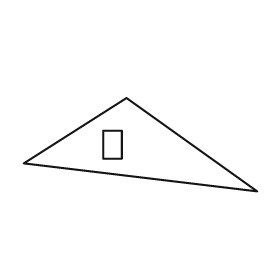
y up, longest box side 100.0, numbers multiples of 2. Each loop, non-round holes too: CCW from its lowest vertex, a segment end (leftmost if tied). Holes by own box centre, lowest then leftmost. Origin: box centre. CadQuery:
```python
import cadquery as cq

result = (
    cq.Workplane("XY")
    .moveTo(50.0, -20.0)
    .lineTo(-6.0, 20.0)
    .lineTo(-50.0, -8.0)
    .close()
    .moveTo(-16.0, -6.0)
    .lineTo(-8.0, -6.0)
    .lineTo(-8.0, 6.0)
    .lineTo(-16.0, 6.0)
    .close()
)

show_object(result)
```